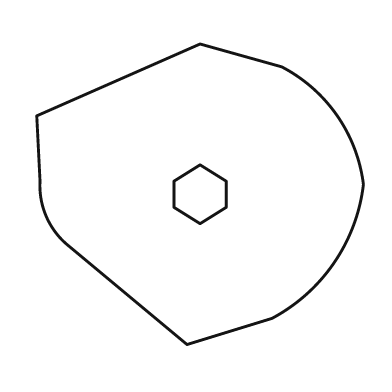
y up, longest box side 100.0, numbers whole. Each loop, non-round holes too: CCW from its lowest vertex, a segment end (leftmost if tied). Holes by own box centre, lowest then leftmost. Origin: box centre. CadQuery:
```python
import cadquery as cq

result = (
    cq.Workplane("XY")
    .moveTo(-4.0, -46.0)
    .lineTo(22.0, -38.0)
    .threePointArc((41.0, -21.0), (50.0, 3.0))
    .threePointArc((42.0, 24.0), (25.0, 39.0))
    .lineTo(0.0, 46.0)
    .lineTo(-50.0, 24.0)
    .lineTo(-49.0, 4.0)
    .threePointArc((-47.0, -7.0), (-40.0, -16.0))
    .close()
    .moveTo(0.0, -9.0)
    .lineTo(8.0, -4.0)
    .lineTo(8.0, 4.0)
    .lineTo(0.0, 9.0)
    .lineTo(-8.0, 4.0)
    .lineTo(-8.0, -4.0)
    .close()
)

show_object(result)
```